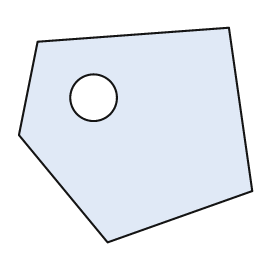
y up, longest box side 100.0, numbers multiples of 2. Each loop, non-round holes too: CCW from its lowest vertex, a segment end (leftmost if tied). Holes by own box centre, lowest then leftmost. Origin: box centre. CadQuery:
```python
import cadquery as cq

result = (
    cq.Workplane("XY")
    .moveTo(-12.0, -46.0)
    .lineTo(50.0, -24.0)
    .lineTo(40.0, 46.0)
    .lineTo(-42.0, 40.0)
    .lineTo(-50.0, 0.0)
    .close()
    .moveTo(-18.0, 16.0)
    .circle(10.0)
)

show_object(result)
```